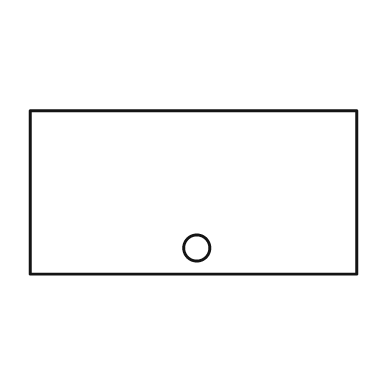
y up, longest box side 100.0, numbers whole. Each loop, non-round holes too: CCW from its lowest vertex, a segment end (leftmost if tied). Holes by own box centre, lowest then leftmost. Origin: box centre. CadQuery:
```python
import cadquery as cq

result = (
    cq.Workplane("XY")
    .moveTo(-50.0, -25.0)
    .lineTo(50.0, -25.0)
    .lineTo(50.0, 25.0)
    .lineTo(-50.0, 25.0)
    .close()
    .moveTo(1.0, -17.0)
    .circle(4.0)
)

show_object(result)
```